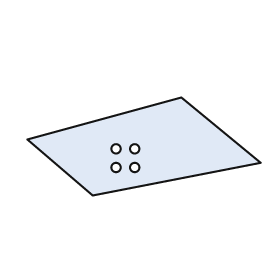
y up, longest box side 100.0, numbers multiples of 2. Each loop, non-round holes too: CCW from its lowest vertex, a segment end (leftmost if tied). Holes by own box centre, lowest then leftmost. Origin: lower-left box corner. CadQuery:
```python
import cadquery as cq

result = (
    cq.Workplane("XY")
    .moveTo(28.0, 0.0)
    .lineTo(100.0, 14.0)
    .lineTo(66.0, 42.0)
    .lineTo(0.0, 24.0)
    .close()
    .moveTo(38.0, 12.0)
    .circle(2.0)
    .moveTo(46.0, 12.0)
    .circle(2.0)
    .moveTo(38.0, 20.0)
    .circle(2.0)
    .moveTo(46.0, 20.0)
    .circle(2.0)
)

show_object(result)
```